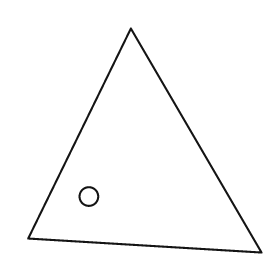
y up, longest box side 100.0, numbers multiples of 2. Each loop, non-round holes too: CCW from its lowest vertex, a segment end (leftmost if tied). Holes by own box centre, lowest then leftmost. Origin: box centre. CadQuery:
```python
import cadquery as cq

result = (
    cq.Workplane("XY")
    .moveTo(50.0, -48.0)
    .lineTo(-6.0, 48.0)
    .lineTo(-50.0, -42.0)
    .close()
    .moveTo(-24.0, -24.0)
    .circle(4.0)
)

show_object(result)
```